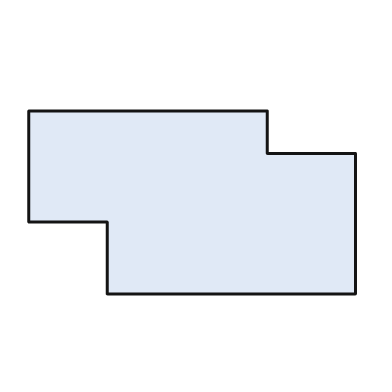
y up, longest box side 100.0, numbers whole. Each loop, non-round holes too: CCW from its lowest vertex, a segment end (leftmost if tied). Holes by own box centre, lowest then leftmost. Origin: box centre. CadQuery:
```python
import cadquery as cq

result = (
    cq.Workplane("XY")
    .moveTo(-26.0, -28.0)
    .lineTo(50.0, -28.0)
    .lineTo(50.0, 15.0)
    .lineTo(23.0, 15.0)
    .lineTo(23.0, 28.0)
    .lineTo(-50.0, 28.0)
    .lineTo(-50.0, -6.0)
    .lineTo(-26.0, -6.0)
    .close()
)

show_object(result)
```